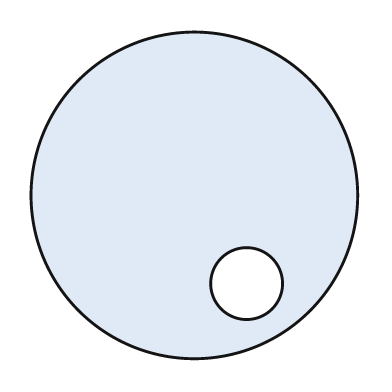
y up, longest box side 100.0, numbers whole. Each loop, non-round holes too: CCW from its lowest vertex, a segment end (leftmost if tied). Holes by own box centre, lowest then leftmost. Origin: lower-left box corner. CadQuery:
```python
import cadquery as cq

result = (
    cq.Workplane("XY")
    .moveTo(50.0, 50.0)
    .circle(50.0)
    .moveTo(66.0, 23.0)
    .circle(11.0)
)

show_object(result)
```